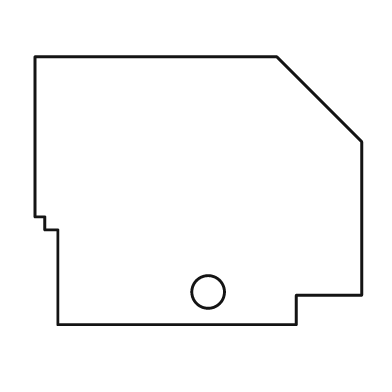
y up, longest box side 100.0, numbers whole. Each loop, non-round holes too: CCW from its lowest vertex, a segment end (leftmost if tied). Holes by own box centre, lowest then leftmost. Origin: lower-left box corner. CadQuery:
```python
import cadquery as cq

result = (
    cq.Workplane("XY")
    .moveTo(7.0, 0.0)
    .lineTo(80.0, 0.0)
    .lineTo(80.0, 9.0)
    .lineTo(100.0, 9.0)
    .lineTo(100.0, 56.0)
    .lineTo(74.0, 82.0)
    .lineTo(0.0, 82.0)
    .lineTo(0.0, 33.0)
    .lineTo(3.0, 33.0)
    .lineTo(3.0, 29.0)
    .lineTo(7.0, 29.0)
    .close()
    .moveTo(53.0, 10.0)
    .circle(5.0)
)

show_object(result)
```